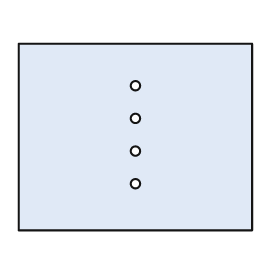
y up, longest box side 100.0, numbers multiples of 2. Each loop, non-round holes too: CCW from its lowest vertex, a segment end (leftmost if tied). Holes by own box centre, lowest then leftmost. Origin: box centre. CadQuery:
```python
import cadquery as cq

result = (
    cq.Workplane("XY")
    .moveTo(-50.0, -40.0)
    .lineTo(50.0, -40.0)
    .lineTo(50.0, 40.0)
    .lineTo(-50.0, 40.0)
    .close()
    .moveTo(0.0, -20.0)
    .circle(2.0)
    .moveTo(0.0, -6.0)
    .circle(2.0)
    .moveTo(0.0, 8.0)
    .circle(2.0)
    .moveTo(0.0, 22.0)
    .circle(2.0)
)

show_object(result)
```